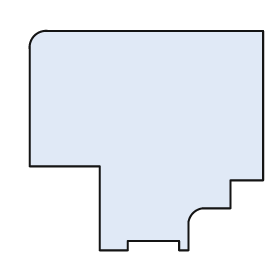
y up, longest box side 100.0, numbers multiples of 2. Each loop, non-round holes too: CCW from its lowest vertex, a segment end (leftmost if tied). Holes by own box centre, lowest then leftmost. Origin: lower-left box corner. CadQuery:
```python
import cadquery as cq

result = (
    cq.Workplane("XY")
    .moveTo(30.0, 0.0)
    .lineTo(42.0, 0.0)
    .lineTo(42.0, 4.0)
    .lineTo(64.0, 4.0)
    .lineTo(64.0, 0.0)
    .lineTo(68.0, 0.0)
    .lineTo(68.0, 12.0)
    .threePointArc((70.0, 16.0), (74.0, 18.0))
    .lineTo(86.0, 18.0)
    .lineTo(86.0, 30.0)
    .lineTo(100.0, 30.0)
    .lineTo(100.0, 94.0)
    .lineTo(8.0, 94.0)
    .threePointArc((2.0, 92.0), (0.0, 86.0))
    .lineTo(0.0, 36.0)
    .lineTo(30.0, 36.0)
    .close()
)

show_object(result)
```